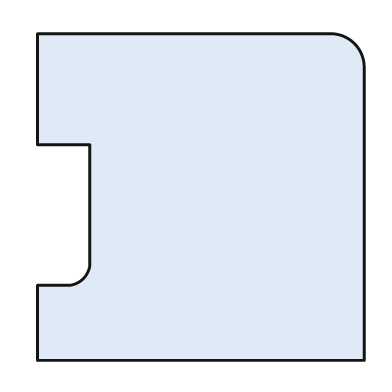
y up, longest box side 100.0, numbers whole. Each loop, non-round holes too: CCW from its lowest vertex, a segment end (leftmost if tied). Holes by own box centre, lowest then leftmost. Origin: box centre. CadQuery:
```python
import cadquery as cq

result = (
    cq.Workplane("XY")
    .moveTo(-50.0, -50.0)
    .lineTo(50.0, -50.0)
    .lineTo(50.0, 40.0)
    .threePointArc((47.0, 47.0), (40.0, 50.0))
    .lineTo(-50.0, 50.0)
    .lineTo(-50.0, 16.0)
    .lineTo(-34.0, 16.0)
    .lineTo(-34.0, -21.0)
    .threePointArc((-36.0, -25.0), (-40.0, -27.0))
    .lineTo(-50.0, -27.0)
    .close()
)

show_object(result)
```